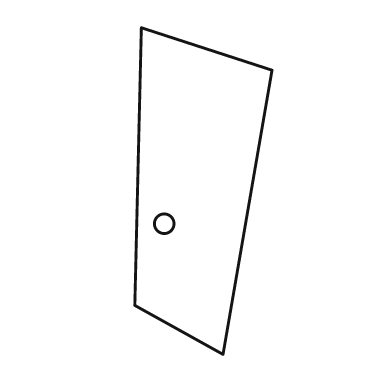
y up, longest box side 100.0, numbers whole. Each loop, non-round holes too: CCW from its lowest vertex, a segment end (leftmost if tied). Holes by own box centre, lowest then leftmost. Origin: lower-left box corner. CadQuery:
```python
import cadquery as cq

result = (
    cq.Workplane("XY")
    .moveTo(27.0, 0.0)
    .lineTo(42.0, 87.0)
    .lineTo(2.0, 100.0)
    .lineTo(0.0, 15.0)
    .close()
    .moveTo(9.0, 40.0)
    .circle(3.0)
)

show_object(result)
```